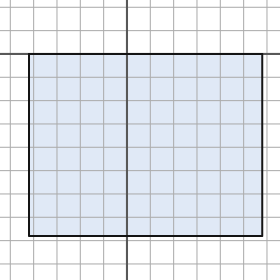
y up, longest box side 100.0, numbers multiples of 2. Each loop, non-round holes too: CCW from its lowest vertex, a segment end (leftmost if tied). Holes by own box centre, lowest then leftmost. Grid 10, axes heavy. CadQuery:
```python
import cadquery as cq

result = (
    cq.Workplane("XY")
    .moveTo(-42.0, -78.0)
    .lineTo(58.0, -78.0)
    .lineTo(58.0, 0.0)
    .lineTo(-42.0, 0.0)
    .close()
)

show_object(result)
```